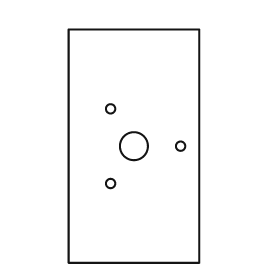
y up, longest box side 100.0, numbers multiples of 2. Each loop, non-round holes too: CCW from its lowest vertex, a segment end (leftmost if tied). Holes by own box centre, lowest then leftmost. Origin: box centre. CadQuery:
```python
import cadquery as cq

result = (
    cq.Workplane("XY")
    .moveTo(-28.0, -50.0)
    .lineTo(28.0, -50.0)
    .lineTo(28.0, 50.0)
    .lineTo(-28.0, 50.0)
    .close()
    .moveTo(-10.0, -16.0)
    .circle(2.0)
    .moveTo(0.0, 0.0)
    .circle(6.0)
    .moveTo(20.0, 0.0)
    .circle(2.0)
    .moveTo(-10.0, 16.0)
    .circle(2.0)
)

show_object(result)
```